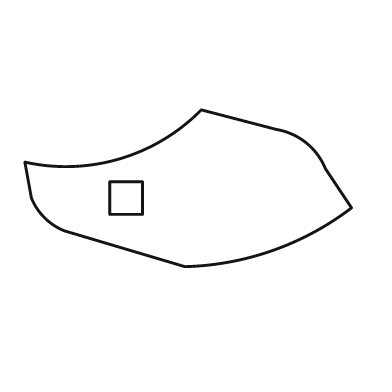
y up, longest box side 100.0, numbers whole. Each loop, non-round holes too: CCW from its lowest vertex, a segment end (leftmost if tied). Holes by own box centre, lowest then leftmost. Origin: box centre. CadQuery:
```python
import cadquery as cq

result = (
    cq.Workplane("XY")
    .moveTo(-1.0, -24.0)
    .threePointArc((26.0, -19.0), (50.0, -6.0))
    .lineTo(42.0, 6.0)
    .threePointArc((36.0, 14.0), (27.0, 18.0))
    .lineTo(4.0, 24.0)
    .threePointArc((-21.0, 9.0), (-50.0, 8.0))
    .lineTo(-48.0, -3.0)
    .threePointArc((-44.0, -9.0), (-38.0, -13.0))
    .close()
    .moveTo(-24.0, -8.0)
    .lineTo(-14.0, -8.0)
    .lineTo(-14.0, 2.0)
    .lineTo(-24.0, 2.0)
    .close()
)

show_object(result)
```